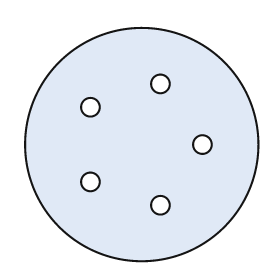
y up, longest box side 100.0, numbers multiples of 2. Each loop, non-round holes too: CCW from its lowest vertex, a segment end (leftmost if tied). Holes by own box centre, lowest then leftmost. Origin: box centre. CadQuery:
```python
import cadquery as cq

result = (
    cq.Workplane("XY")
    .moveTo(0.0, 0.0)
    .circle(50.0)
    .moveTo(8.0, -26.0)
    .circle(4.0)
    .moveTo(-22.0, -16.0)
    .circle(4.0)
    .moveTo(26.0, 0.0)
    .circle(4.0)
    .moveTo(-22.0, 16.0)
    .circle(4.0)
    .moveTo(8.0, 26.0)
    .circle(4.0)
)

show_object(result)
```